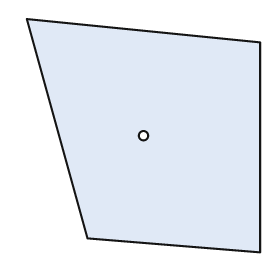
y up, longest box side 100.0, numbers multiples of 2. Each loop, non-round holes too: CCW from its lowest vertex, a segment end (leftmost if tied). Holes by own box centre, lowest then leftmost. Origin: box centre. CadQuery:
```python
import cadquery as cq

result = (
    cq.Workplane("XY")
    .moveTo(50.0, -50.0)
    .lineTo(50.0, 40.0)
    .lineTo(-50.0, 50.0)
    .lineTo(-24.0, -44.0)
    .close()
    .moveTo(0.0, 0.0)
    .circle(2.0)
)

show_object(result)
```